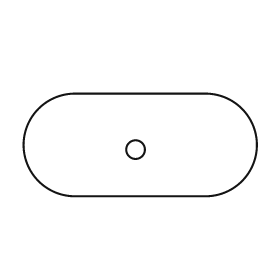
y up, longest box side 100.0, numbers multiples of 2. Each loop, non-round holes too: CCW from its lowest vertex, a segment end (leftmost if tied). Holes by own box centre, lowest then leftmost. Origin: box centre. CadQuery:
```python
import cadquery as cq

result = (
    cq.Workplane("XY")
    .moveTo(-28.0, -22.0)
    .lineTo(28.0, -22.0)
    .threePointArc((50.0, 0.0), (28.0, 22.0))
    .lineTo(-28.0, 22.0)
    .threePointArc((-50.0, 0.0), (-28.0, -22.0))
    .close()
    .moveTo(-2.0, -2.0)
    .circle(4.0)
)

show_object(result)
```